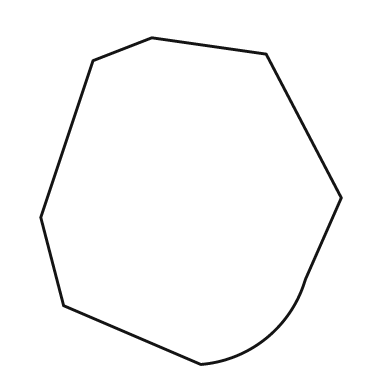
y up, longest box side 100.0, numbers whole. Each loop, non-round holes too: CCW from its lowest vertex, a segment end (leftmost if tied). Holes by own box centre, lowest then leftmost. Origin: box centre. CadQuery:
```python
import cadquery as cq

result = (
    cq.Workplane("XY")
    .moveTo(3.0, -50.0)
    .threePointArc((23.0, -42.0), (35.0, -24.0))
    .lineTo(46.0, 1.0)
    .lineTo(23.0, 45.0)
    .lineTo(-12.0, 50.0)
    .lineTo(-30.0, 43.0)
    .lineTo(-46.0, -5.0)
    .lineTo(-39.0, -32.0)
    .close()
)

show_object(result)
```